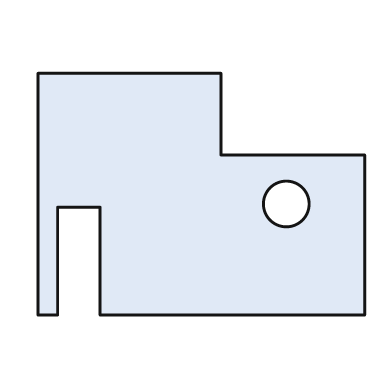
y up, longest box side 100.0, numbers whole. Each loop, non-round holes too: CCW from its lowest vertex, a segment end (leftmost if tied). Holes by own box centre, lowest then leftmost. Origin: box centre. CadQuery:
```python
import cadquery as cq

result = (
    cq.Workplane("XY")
    .moveTo(-50.0, -37.0)
    .lineTo(-44.0, -37.0)
    .lineTo(-44.0, -4.0)
    .lineTo(-31.0, -4.0)
    .lineTo(-31.0, -37.0)
    .lineTo(50.0, -37.0)
    .lineTo(50.0, 12.0)
    .lineTo(6.0, 12.0)
    .lineTo(6.0, 37.0)
    .lineTo(-50.0, 37.0)
    .close()
    .moveTo(26.0, -3.0)
    .circle(7.0)
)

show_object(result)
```